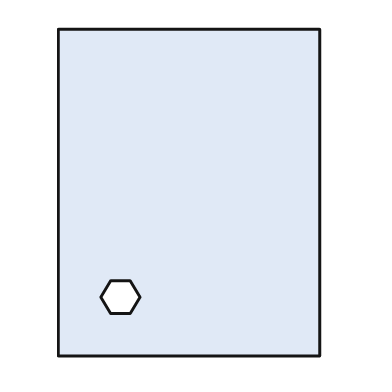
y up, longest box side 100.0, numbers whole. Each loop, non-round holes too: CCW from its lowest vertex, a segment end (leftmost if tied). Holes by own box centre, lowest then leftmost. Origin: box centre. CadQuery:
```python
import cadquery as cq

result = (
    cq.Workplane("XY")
    .moveTo(-40.0, -50.0)
    .lineTo(40.0, -50.0)
    .lineTo(40.0, 50.0)
    .lineTo(-40.0, 50.0)
    .close()
    .moveTo(-24.0, -37.0)
    .lineTo(-18.0, -37.0)
    .lineTo(-15.0, -32.0)
    .lineTo(-18.0, -27.0)
    .lineTo(-24.0, -27.0)
    .lineTo(-27.0, -32.0)
    .close()
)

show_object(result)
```